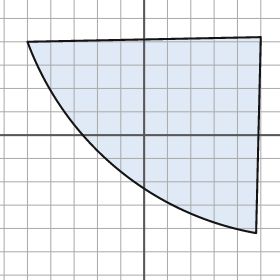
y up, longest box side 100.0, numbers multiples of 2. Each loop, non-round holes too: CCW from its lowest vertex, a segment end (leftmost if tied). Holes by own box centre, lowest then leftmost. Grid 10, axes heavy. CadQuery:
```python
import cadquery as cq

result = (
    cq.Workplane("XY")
    .moveTo(48.0, -42.0)
    .lineTo(50.0, 42.0)
    .lineTo(-50.0, 40.0)
    .threePointArc((-12.0, -14.0), (48.0, -42.0))
    .close()
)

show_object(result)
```